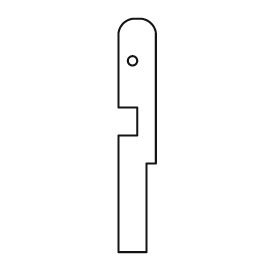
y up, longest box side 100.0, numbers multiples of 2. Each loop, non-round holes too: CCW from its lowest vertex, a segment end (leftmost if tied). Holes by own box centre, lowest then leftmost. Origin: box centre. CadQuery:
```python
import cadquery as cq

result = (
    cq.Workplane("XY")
    .moveTo(-8.0, -50.0)
    .lineTo(4.0, -50.0)
    .lineTo(4.0, -12.0)
    .lineTo(8.0, -12.0)
    .lineTo(8.0, 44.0)
    .threePointArc((6.0, 48.0), (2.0, 50.0))
    .lineTo(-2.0, 50.0)
    .threePointArc((-6.0, 48.0), (-8.0, 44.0))
    .lineTo(-8.0, 12.0)
    .lineTo(0.0, 12.0)
    .lineTo(0.0, 0.0)
    .lineTo(-8.0, 0.0)
    .close()
    .moveTo(-2.0, 32.0)
    .circle(2.0)
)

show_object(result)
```